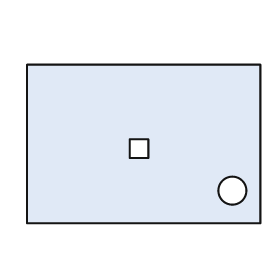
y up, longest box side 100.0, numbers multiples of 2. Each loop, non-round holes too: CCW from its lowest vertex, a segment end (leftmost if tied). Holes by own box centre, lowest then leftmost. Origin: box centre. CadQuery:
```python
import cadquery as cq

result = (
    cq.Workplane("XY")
    .moveTo(-50.0, -34.0)
    .lineTo(50.0, -34.0)
    .lineTo(50.0, 34.0)
    .lineTo(-50.0, 34.0)
    .close()
    .moveTo(38.0, -20.0)
    .circle(6.0)
    .moveTo(-6.0, -6.0)
    .lineTo(2.0, -6.0)
    .lineTo(2.0, 2.0)
    .lineTo(-6.0, 2.0)
    .close()
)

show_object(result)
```